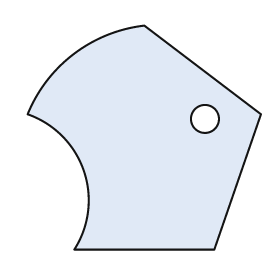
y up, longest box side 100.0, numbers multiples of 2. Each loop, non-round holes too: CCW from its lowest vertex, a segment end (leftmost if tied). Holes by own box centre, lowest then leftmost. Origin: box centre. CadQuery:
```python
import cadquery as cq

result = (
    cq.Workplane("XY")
    .moveTo(-30.0, -48.0)
    .lineTo(30.0, -48.0)
    .lineTo(50.0, 10.0)
    .lineTo(0.0, 48.0)
    .threePointArc((-30.0, 36.0), (-50.0, 10.0))
    .threePointArc((-26.0, -14.0), (-30.0, -48.0))
    .close()
    .moveTo(26.0, 8.0)
    .circle(6.0)
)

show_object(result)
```